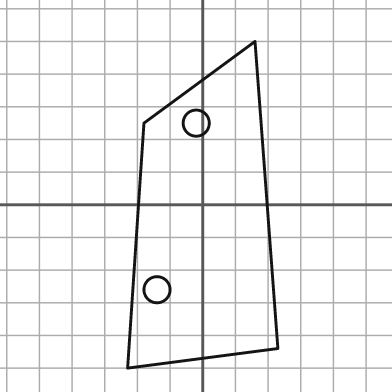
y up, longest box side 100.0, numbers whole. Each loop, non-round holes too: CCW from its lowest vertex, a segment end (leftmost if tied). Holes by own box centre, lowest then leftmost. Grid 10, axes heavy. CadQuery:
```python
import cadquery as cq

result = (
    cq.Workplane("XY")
    .moveTo(-23.0, -50.0)
    .lineTo(23.0, -44.0)
    .lineTo(16.0, 50.0)
    .lineTo(-18.0, 25.0)
    .close()
    .moveTo(-14.0, -26.0)
    .circle(4.0)
    .moveTo(-2.0, 25.0)
    .circle(4.0)
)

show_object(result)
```